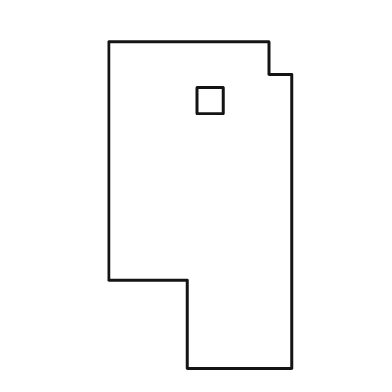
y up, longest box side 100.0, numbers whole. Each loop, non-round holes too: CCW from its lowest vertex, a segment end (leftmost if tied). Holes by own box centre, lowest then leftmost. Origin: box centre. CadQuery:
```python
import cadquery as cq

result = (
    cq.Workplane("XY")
    .moveTo(-4.0, -50.0)
    .lineTo(28.0, -50.0)
    .lineTo(28.0, 40.0)
    .lineTo(21.0, 40.0)
    .lineTo(21.0, 50.0)
    .lineTo(-28.0, 50.0)
    .lineTo(-28.0, -23.0)
    .lineTo(-4.0, -23.0)
    .close()
    .moveTo(-1.0, 28.0)
    .lineTo(7.0, 28.0)
    .lineTo(7.0, 36.0)
    .lineTo(-1.0, 36.0)
    .close()
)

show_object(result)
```